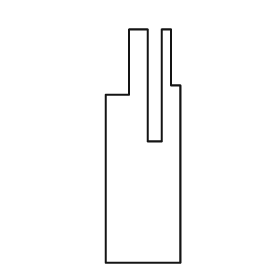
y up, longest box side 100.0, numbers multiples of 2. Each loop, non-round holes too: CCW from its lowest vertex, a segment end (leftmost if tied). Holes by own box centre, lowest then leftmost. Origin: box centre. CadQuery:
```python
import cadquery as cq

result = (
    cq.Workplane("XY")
    .moveTo(-16.0, -50.0)
    .lineTo(16.0, -50.0)
    .lineTo(16.0, 26.0)
    .lineTo(12.0, 26.0)
    .lineTo(12.0, 50.0)
    .lineTo(8.0, 50.0)
    .lineTo(8.0, 2.0)
    .lineTo(2.0, 2.0)
    .lineTo(2.0, 50.0)
    .lineTo(-6.0, 50.0)
    .lineTo(-6.0, 22.0)
    .lineTo(-16.0, 22.0)
    .close()
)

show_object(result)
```